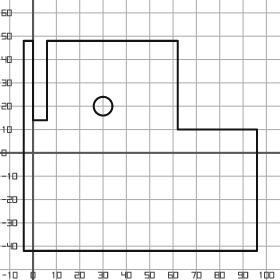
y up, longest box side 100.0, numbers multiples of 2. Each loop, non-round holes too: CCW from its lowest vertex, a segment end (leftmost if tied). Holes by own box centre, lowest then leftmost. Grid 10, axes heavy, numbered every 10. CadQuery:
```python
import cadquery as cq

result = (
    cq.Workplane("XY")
    .moveTo(-4.0, -42.0)
    .lineTo(96.0, -42.0)
    .lineTo(96.0, 10.0)
    .lineTo(62.0, 10.0)
    .lineTo(62.0, 48.0)
    .lineTo(6.0, 48.0)
    .lineTo(6.0, 14.0)
    .lineTo(0.0, 14.0)
    .lineTo(0.0, 48.0)
    .lineTo(-4.0, 48.0)
    .close()
    .moveTo(30.0, 20.0)
    .circle(4.0)
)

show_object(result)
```